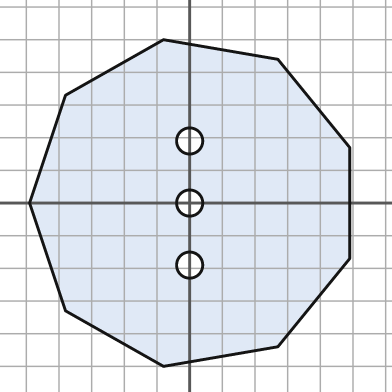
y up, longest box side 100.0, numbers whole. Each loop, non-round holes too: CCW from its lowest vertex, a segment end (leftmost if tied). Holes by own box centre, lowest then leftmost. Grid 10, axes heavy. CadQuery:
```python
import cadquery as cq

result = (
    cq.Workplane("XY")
    .moveTo(-8.0, -50.0)
    .lineTo(27.0, -44.0)
    .lineTo(49.0, -17.0)
    .lineTo(49.0, 17.0)
    .lineTo(27.0, 44.0)
    .lineTo(-8.0, 50.0)
    .lineTo(-38.0, 33.0)
    .lineTo(-49.0, 0.0)
    .lineTo(-38.0, -33.0)
    .close()
    .moveTo(0.0, -19.0)
    .circle(4.0)
    .moveTo(0.0, 0.0)
    .circle(4.0)
    .moveTo(0.0, 19.0)
    .circle(4.0)
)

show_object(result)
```